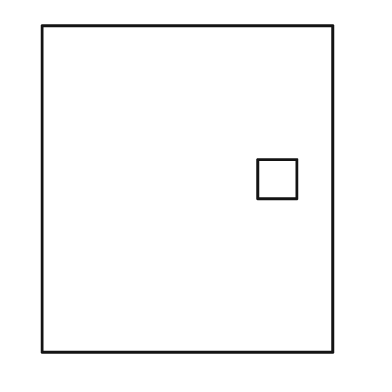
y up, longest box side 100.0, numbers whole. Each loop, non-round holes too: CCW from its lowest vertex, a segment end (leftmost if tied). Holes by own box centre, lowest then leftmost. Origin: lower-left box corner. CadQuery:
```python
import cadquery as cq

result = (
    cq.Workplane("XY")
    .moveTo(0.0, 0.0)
    .lineTo(89.0, 0.0)
    .lineTo(89.0, 100.0)
    .lineTo(0.0, 100.0)
    .close()
    .moveTo(66.0, 47.0)
    .lineTo(78.0, 47.0)
    .lineTo(78.0, 59.0)
    .lineTo(66.0, 59.0)
    .close()
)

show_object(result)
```